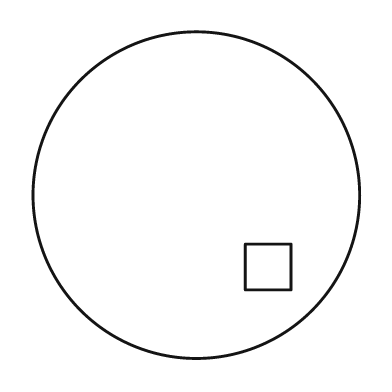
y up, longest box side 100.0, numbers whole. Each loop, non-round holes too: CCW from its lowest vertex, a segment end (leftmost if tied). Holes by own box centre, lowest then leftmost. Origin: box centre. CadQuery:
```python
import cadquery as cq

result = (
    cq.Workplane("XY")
    .moveTo(0.0, 0.0)
    .circle(50.0)
    .moveTo(15.0, -29.0)
    .lineTo(29.0, -29.0)
    .lineTo(29.0, -15.0)
    .lineTo(15.0, -15.0)
    .close()
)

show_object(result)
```